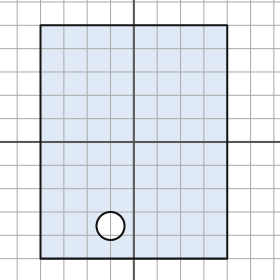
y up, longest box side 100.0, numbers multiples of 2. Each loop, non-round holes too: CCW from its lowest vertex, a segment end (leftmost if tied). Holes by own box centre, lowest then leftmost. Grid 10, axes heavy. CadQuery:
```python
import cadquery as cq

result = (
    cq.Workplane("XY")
    .moveTo(-40.0, -50.0)
    .lineTo(40.0, -50.0)
    .lineTo(40.0, 50.0)
    .lineTo(-40.0, 50.0)
    .close()
    .moveTo(-10.0, -36.0)
    .circle(6.0)
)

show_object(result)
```